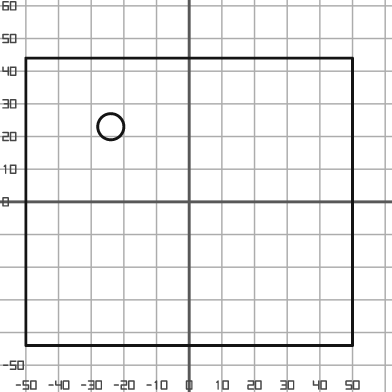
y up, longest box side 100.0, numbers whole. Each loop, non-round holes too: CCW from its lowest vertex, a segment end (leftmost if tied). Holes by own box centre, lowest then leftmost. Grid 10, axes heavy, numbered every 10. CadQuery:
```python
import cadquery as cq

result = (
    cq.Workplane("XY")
    .moveTo(-50.0, -44.0)
    .lineTo(50.0, -44.0)
    .lineTo(50.0, 44.0)
    .lineTo(-50.0, 44.0)
    .close()
    .moveTo(-24.0, 23.0)
    .circle(4.0)
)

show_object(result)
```